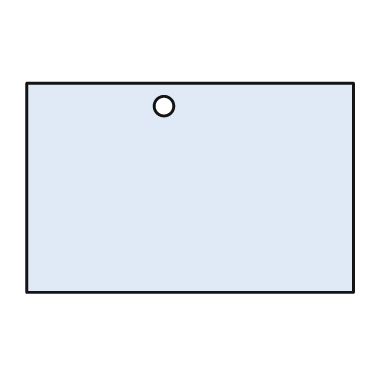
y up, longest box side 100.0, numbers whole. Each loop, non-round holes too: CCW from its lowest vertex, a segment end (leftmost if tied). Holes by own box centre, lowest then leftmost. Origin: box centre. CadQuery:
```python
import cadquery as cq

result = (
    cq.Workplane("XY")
    .moveTo(-50.0, -32.0)
    .lineTo(50.0, -32.0)
    .lineTo(50.0, 32.0)
    .lineTo(-50.0, 32.0)
    .close()
    .moveTo(-8.0, 25.0)
    .circle(3.0)
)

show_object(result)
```